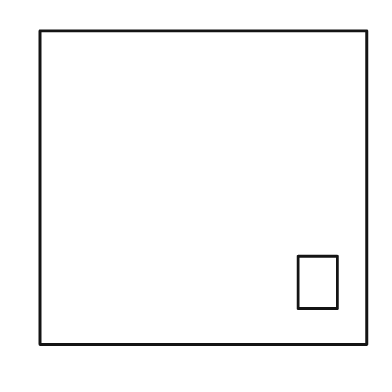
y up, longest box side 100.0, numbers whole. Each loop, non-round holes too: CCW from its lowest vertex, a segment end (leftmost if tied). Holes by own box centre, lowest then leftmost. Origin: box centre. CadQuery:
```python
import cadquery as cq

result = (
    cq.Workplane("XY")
    .moveTo(-50.0, -48.0)
    .lineTo(50.0, -48.0)
    .lineTo(50.0, 48.0)
    .lineTo(-50.0, 48.0)
    .close()
    .moveTo(29.0, -37.0)
    .lineTo(41.0, -37.0)
    .lineTo(41.0, -21.0)
    .lineTo(29.0, -21.0)
    .close()
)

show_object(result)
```